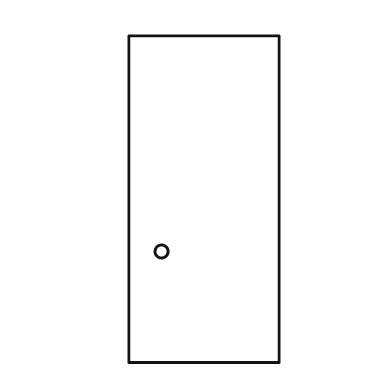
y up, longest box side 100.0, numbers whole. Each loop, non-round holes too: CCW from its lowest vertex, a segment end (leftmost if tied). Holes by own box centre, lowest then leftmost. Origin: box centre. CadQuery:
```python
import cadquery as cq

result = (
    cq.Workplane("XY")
    .moveTo(-23.0, -50.0)
    .lineTo(23.0, -50.0)
    .lineTo(23.0, 50.0)
    .lineTo(-23.0, 50.0)
    .close()
    .moveTo(-13.0, -16.0)
    .circle(2.0)
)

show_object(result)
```